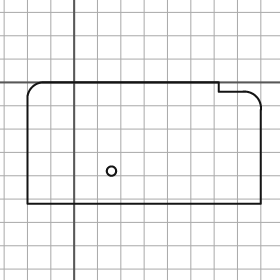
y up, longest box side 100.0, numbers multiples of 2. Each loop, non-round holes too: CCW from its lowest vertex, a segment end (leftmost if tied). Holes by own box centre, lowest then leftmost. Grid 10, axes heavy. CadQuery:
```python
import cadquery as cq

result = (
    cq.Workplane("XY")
    .moveTo(-20.0, -52.0)
    .lineTo(80.0, -52.0)
    .lineTo(80.0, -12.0)
    .threePointArc((78.0, -6.0), (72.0, -4.0))
    .lineTo(62.0, -4.0)
    .lineTo(62.0, 0.0)
    .lineTo(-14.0, 0.0)
    .threePointArc((-18.0, -2.0), (-20.0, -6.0))
    .close()
    .moveTo(16.0, -38.0)
    .circle(2.0)
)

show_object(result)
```